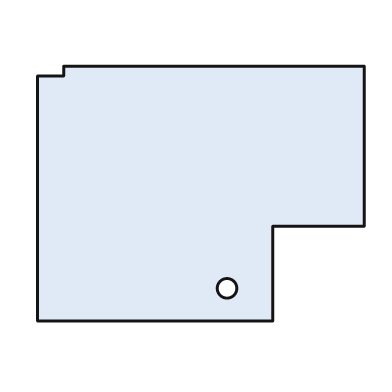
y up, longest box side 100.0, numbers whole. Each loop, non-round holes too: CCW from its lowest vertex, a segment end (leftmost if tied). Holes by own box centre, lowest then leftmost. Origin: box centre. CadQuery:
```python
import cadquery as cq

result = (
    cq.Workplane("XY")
    .moveTo(-50.0, -39.0)
    .lineTo(22.0, -39.0)
    .lineTo(22.0, -10.0)
    .lineTo(50.0, -10.0)
    .lineTo(50.0, 39.0)
    .lineTo(-42.0, 39.0)
    .lineTo(-42.0, 36.0)
    .lineTo(-50.0, 36.0)
    .close()
    .moveTo(8.0, -29.0)
    .circle(3.0)
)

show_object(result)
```